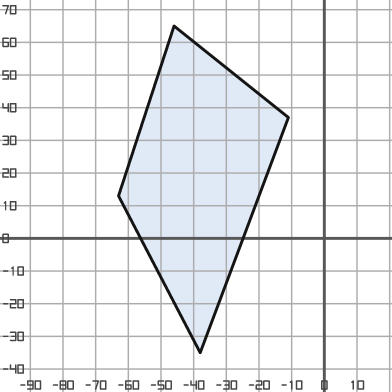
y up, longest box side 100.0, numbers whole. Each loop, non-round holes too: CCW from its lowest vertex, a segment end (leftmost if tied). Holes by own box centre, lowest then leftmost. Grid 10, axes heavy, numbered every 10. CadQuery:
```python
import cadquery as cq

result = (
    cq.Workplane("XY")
    .moveTo(-38.0, -35.0)
    .lineTo(-11.0, 37.0)
    .lineTo(-46.0, 65.0)
    .lineTo(-63.0, 13.0)
    .close()
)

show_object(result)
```